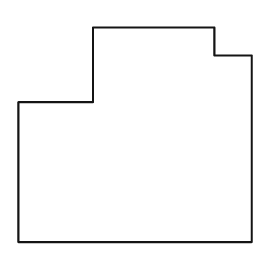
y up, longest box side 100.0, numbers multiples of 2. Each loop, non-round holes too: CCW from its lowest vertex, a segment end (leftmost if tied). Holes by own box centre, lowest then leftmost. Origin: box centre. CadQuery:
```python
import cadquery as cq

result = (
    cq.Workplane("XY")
    .moveTo(-50.0, -46.0)
    .lineTo(50.0, -46.0)
    .lineTo(50.0, 34.0)
    .lineTo(34.0, 34.0)
    .lineTo(34.0, 46.0)
    .lineTo(-18.0, 46.0)
    .lineTo(-18.0, 14.0)
    .lineTo(-50.0, 14.0)
    .close()
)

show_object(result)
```